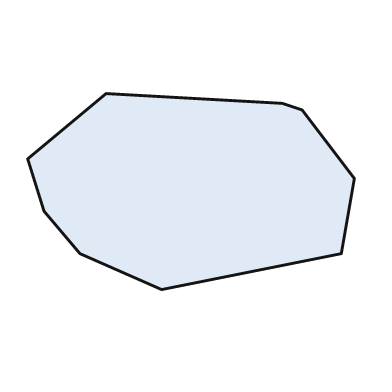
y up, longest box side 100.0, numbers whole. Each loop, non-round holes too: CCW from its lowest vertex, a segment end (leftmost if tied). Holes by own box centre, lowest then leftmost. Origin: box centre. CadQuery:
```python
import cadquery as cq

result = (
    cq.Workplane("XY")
    .moveTo(-9.0, -30.0)
    .lineTo(46.0, -19.0)
    .lineTo(50.0, 4.0)
    .lineTo(34.0, 25.0)
    .lineTo(28.0, 27.0)
    .lineTo(-26.0, 30.0)
    .lineTo(-50.0, 10.0)
    .lineTo(-45.0, -6.0)
    .lineTo(-34.0, -19.0)
    .close()
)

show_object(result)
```